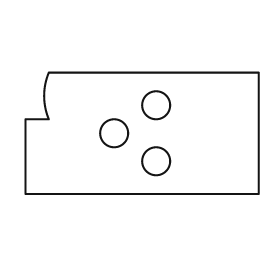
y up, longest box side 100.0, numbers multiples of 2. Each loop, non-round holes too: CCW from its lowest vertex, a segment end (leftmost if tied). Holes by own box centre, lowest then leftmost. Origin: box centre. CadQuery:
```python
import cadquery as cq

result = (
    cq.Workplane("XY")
    .moveTo(-50.0, -26.0)
    .lineTo(50.0, -26.0)
    .lineTo(50.0, 26.0)
    .lineTo(-40.0, 26.0)
    .threePointArc((-42.0, 16.0), (-40.0, 6.0))
    .lineTo(-50.0, 6.0)
    .close()
    .moveTo(6.0, -12.0)
    .circle(6.0)
    .moveTo(-12.0, 0.0)
    .circle(6.0)
    .moveTo(6.0, 12.0)
    .circle(6.0)
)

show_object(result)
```